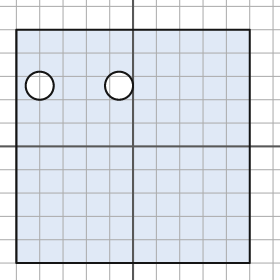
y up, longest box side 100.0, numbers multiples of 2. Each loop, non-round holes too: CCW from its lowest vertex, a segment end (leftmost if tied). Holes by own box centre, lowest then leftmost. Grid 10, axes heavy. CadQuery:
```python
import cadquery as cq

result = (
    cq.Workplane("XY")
    .moveTo(-50.0, -50.0)
    .lineTo(50.0, -50.0)
    .lineTo(50.0, 50.0)
    .lineTo(-50.0, 50.0)
    .close()
    .moveTo(-40.0, 26.0)
    .circle(6.0)
    .moveTo(-6.0, 26.0)
    .circle(6.0)
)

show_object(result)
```